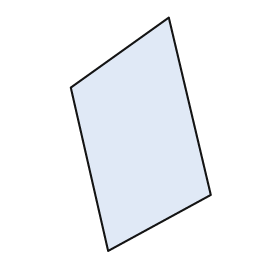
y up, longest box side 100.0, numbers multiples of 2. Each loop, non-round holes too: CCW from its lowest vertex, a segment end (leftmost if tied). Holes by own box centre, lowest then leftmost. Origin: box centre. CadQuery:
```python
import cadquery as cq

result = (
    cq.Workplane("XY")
    .moveTo(-14.0, -50.0)
    .lineTo(30.0, -26.0)
    .lineTo(12.0, 50.0)
    .lineTo(-30.0, 20.0)
    .close()
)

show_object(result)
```